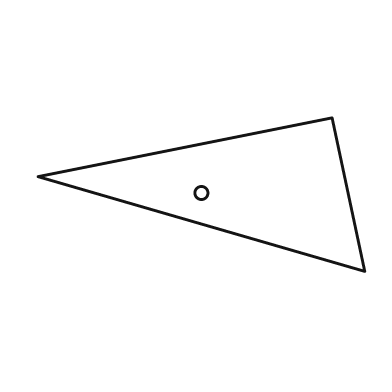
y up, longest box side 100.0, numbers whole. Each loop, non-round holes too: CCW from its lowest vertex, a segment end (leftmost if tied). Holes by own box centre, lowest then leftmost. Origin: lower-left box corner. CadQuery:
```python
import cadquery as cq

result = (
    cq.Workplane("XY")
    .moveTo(100.0, 0.0)
    .lineTo(90.0, 47.0)
    .lineTo(0.0, 29.0)
    .close()
    .moveTo(50.0, 24.0)
    .circle(2.0)
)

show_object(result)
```